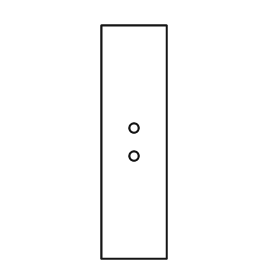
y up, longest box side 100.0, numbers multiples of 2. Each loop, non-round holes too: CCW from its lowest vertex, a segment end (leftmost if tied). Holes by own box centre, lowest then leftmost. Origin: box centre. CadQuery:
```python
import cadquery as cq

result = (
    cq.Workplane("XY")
    .moveTo(-14.0, -50.0)
    .lineTo(14.0, -50.0)
    .lineTo(14.0, 50.0)
    .lineTo(-14.0, 50.0)
    .close()
    .moveTo(0.0, -6.0)
    .circle(2.0)
    .moveTo(0.0, 6.0)
    .circle(2.0)
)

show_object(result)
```